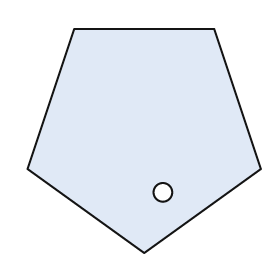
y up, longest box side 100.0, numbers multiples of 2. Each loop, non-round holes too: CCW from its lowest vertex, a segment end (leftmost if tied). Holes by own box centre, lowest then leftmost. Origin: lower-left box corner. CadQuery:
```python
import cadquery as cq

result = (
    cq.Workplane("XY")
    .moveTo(50.0, 0.0)
    .lineTo(100.0, 36.0)
    .lineTo(80.0, 96.0)
    .lineTo(20.0, 96.0)
    .lineTo(0.0, 36.0)
    .close()
    .moveTo(58.0, 26.0)
    .circle(4.0)
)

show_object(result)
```